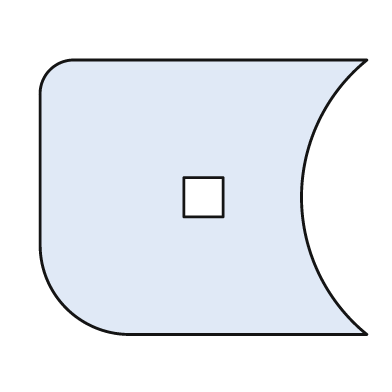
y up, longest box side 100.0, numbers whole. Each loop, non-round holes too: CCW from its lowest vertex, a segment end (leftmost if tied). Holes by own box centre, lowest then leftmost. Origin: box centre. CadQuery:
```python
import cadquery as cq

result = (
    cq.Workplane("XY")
    .moveTo(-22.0, -42.0)
    .lineTo(50.0, -42.0)
    .threePointArc((30.0, 0.0), (50.0, 42.0))
    .lineTo(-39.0, 42.0)
    .threePointArc((-47.0, 39.0), (-50.0, 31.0))
    .lineTo(-50.0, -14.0)
    .threePointArc((-42.0, -34.0), (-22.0, -42.0))
    .close()
    .moveTo(-6.0, -6.0)
    .lineTo(6.0, -6.0)
    .lineTo(6.0, 6.0)
    .lineTo(-6.0, 6.0)
    .close()
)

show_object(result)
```